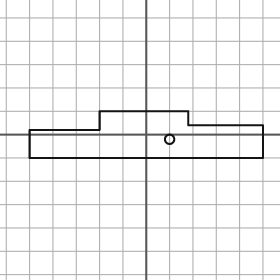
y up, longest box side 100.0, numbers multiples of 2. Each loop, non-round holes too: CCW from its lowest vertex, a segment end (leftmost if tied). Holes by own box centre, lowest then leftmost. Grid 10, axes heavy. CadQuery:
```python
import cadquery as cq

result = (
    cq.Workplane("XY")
    .moveTo(-50.0, -10.0)
    .lineTo(50.0, -10.0)
    .lineTo(50.0, 4.0)
    .lineTo(18.0, 4.0)
    .lineTo(18.0, 10.0)
    .lineTo(-20.0, 10.0)
    .lineTo(-20.0, 2.0)
    .lineTo(-50.0, 2.0)
    .close()
    .moveTo(10.0, -2.0)
    .circle(2.0)
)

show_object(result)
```